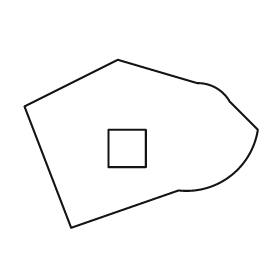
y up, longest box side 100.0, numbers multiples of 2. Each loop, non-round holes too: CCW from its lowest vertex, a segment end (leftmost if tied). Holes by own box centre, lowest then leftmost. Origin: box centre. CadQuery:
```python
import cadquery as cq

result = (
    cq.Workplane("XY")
    .moveTo(-30.0, -36.0)
    .lineTo(16.0, -20.0)
    .threePointArc((38.0, -14.0), (50.0, 6.0))
    .lineTo(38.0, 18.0)
    .threePointArc((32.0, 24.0), (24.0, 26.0))
    .lineTo(-10.0, 36.0)
    .lineTo(-50.0, 16.0)
    .close()
    .moveTo(-14.0, -10.0)
    .lineTo(2.0, -10.0)
    .lineTo(2.0, 6.0)
    .lineTo(-14.0, 6.0)
    .close()
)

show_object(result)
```